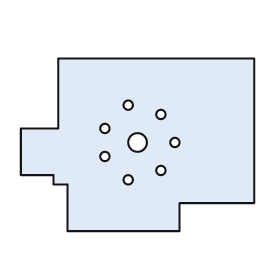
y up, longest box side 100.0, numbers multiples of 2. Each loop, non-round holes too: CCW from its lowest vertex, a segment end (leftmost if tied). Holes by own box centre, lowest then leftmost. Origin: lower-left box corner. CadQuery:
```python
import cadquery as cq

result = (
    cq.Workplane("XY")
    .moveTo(20.0, 0.0)
    .lineTo(68.0, 0.0)
    .lineTo(68.0, 12.0)
    .lineTo(100.0, 12.0)
    .lineTo(100.0, 74.0)
    .lineTo(16.0, 74.0)
    .lineTo(16.0, 44.0)
    .lineTo(0.0, 44.0)
    .lineTo(0.0, 24.0)
    .lineTo(14.0, 24.0)
    .lineTo(14.0, 20.0)
    .lineTo(20.0, 20.0)
    .close()
    .moveTo(46.0, 22.0)
    .circle(2.0)
    .moveTo(60.0, 26.0)
    .circle(2.0)
    .moveTo(36.0, 32.0)
    .circle(2.0)
    .moveTo(50.0, 38.0)
    .circle(4.0)
    .moveTo(66.0, 38.0)
    .circle(2.0)
    .moveTo(36.0, 44.0)
    .circle(2.0)
    .moveTo(60.0, 50.0)
    .circle(2.0)
    .moveTo(46.0, 54.0)
    .circle(2.0)
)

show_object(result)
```